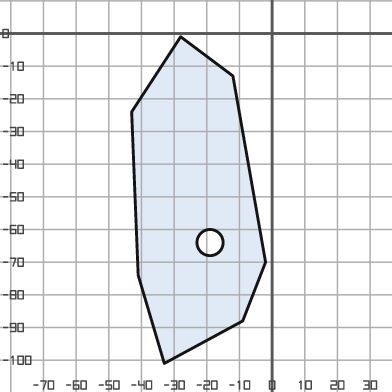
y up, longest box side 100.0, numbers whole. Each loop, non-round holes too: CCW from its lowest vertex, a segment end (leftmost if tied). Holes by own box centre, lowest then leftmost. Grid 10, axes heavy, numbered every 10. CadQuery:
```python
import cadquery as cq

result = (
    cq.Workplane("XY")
    .moveTo(-33.0, -101.0)
    .lineTo(-9.0, -88.0)
    .lineTo(-2.0, -70.0)
    .lineTo(-12.0, -13.0)
    .lineTo(-28.0, -1.0)
    .lineTo(-43.0, -24.0)
    .lineTo(-41.0, -74.0)
    .close()
    .moveTo(-19.0, -64.0)
    .circle(4.0)
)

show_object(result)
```